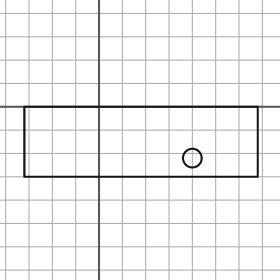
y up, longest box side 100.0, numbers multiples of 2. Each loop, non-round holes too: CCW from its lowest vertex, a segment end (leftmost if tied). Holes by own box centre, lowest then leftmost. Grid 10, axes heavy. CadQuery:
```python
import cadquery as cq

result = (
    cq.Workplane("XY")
    .moveTo(-32.0, -30.0)
    .lineTo(68.0, -30.0)
    .lineTo(68.0, 0.0)
    .lineTo(-32.0, 0.0)
    .close()
    .moveTo(40.0, -22.0)
    .circle(4.0)
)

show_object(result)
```